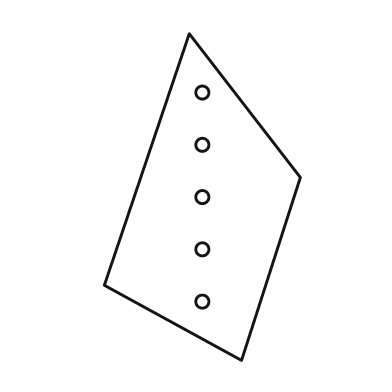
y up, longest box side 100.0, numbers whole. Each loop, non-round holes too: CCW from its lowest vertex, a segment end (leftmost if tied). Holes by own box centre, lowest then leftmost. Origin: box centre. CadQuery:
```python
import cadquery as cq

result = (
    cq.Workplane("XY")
    .moveTo(12.0, -50.0)
    .lineTo(30.0, 6.0)
    .lineTo(-4.0, 50.0)
    .lineTo(-30.0, -27.0)
    .close()
    .moveTo(0.0, -32.0)
    .circle(2.0)
    .moveTo(0.0, -16.0)
    .circle(2.0)
    .moveTo(0.0, 0.0)
    .circle(2.0)
    .moveTo(0.0, 16.0)
    .circle(2.0)
    .moveTo(0.0, 32.0)
    .circle(2.0)
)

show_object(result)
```